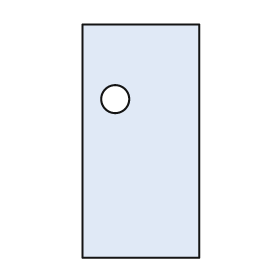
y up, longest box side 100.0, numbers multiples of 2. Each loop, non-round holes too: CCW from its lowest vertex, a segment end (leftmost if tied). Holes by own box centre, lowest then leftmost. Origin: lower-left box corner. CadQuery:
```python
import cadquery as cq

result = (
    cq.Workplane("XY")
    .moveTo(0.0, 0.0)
    .lineTo(50.0, 0.0)
    .lineTo(50.0, 100.0)
    .lineTo(0.0, 100.0)
    .close()
    .moveTo(14.0, 68.0)
    .circle(6.0)
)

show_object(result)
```